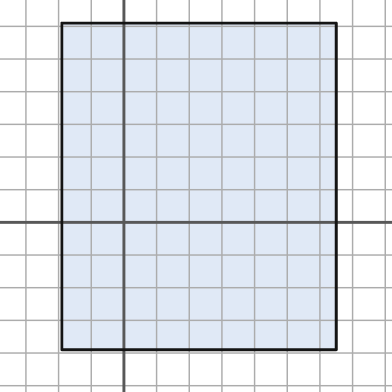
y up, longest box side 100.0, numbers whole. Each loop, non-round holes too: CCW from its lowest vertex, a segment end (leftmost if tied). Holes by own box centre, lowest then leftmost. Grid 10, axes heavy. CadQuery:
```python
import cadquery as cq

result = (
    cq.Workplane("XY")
    .moveTo(-19.0, -39.0)
    .lineTo(65.0, -39.0)
    .lineTo(65.0, 61.0)
    .lineTo(-19.0, 61.0)
    .close()
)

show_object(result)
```